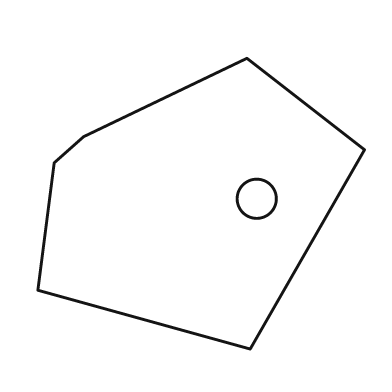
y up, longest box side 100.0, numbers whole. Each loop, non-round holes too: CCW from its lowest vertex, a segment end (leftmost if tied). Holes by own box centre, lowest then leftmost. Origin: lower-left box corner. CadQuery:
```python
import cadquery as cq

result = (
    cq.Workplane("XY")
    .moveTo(65.0, 0.0)
    .lineTo(100.0, 61.0)
    .lineTo(64.0, 89.0)
    .lineTo(14.0, 65.0)
    .lineTo(5.0, 57.0)
    .lineTo(0.0, 18.0)
    .close()
    .moveTo(67.0, 46.0)
    .circle(6.0)
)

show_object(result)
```